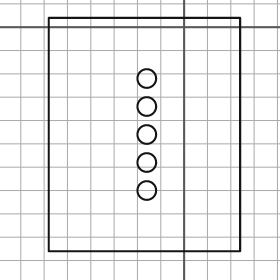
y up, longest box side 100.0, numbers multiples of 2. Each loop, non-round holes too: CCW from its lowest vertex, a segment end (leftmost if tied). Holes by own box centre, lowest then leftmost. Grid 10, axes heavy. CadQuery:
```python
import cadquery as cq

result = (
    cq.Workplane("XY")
    .moveTo(-58.0, -96.0)
    .lineTo(24.0, -96.0)
    .lineTo(24.0, 4.0)
    .lineTo(-58.0, 4.0)
    .close()
    .moveTo(-16.0, -70.0)
    .circle(4.0)
    .moveTo(-16.0, -58.0)
    .circle(4.0)
    .moveTo(-16.0, -46.0)
    .circle(4.0)
    .moveTo(-16.0, -34.0)
    .circle(4.0)
    .moveTo(-16.0, -22.0)
    .circle(4.0)
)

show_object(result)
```